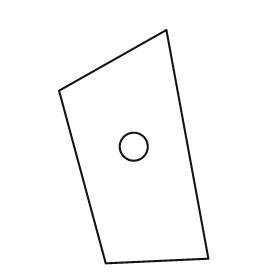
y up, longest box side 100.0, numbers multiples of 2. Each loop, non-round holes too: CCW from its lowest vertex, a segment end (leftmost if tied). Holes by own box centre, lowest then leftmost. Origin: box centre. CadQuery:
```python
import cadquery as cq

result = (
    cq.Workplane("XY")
    .moveTo(-12.0, -50.0)
    .lineTo(32.0, -48.0)
    .lineTo(14.0, 50.0)
    .lineTo(-32.0, 24.0)
    .close()
    .moveTo(0.0, 0.0)
    .circle(6.0)
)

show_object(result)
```